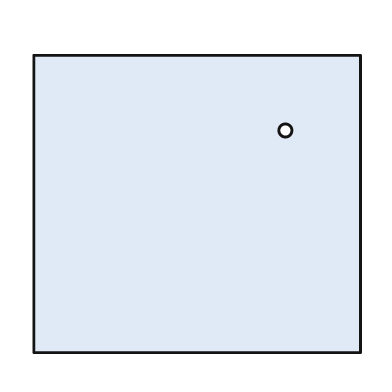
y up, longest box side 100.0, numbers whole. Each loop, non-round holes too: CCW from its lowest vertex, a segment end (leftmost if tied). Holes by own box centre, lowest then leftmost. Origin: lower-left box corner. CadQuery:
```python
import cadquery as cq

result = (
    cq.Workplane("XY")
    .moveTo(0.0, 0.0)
    .lineTo(100.0, 0.0)
    .lineTo(100.0, 91.0)
    .lineTo(0.0, 91.0)
    .close()
    .moveTo(77.0, 68.0)
    .circle(2.0)
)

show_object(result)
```